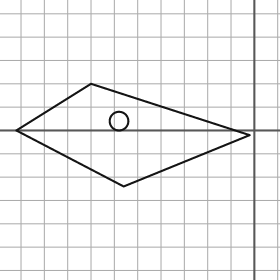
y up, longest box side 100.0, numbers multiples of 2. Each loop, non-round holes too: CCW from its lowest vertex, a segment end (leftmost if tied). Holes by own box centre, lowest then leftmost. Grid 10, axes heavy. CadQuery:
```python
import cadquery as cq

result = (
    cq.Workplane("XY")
    .moveTo(-56.0, -24.0)
    .lineTo(-2.0, -2.0)
    .lineTo(-70.0, 20.0)
    .lineTo(-102.0, 0.0)
    .close()
    .moveTo(-58.0, 4.0)
    .circle(4.0)
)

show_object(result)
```